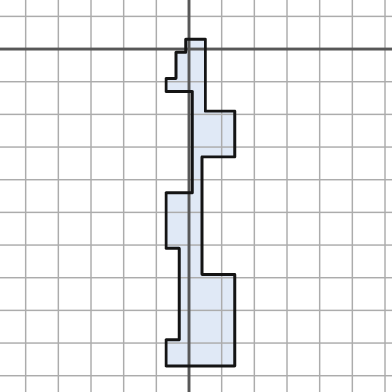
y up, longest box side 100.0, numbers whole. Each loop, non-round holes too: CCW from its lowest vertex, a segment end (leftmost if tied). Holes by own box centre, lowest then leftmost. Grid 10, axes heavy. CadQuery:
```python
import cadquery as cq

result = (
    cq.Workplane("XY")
    .moveTo(-7.0, -97.0)
    .lineTo(14.0, -97.0)
    .lineTo(14.0, -69.0)
    .lineTo(4.0, -69.0)
    .lineTo(4.0, -33.0)
    .lineTo(14.0, -33.0)
    .lineTo(14.0, -19.0)
    .lineTo(5.0, -19.0)
    .lineTo(5.0, 3.0)
    .lineTo(-1.0, 3.0)
    .lineTo(-1.0, -1.0)
    .lineTo(-4.0, -1.0)
    .lineTo(-4.0, -9.0)
    .lineTo(-7.0, -9.0)
    .lineTo(-7.0, -13.0)
    .lineTo(1.0, -13.0)
    .lineTo(1.0, -44.0)
    .lineTo(-7.0, -44.0)
    .lineTo(-7.0, -61.0)
    .lineTo(-3.0, -61.0)
    .lineTo(-3.0, -89.0)
    .lineTo(-7.0, -89.0)
    .close()
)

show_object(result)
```